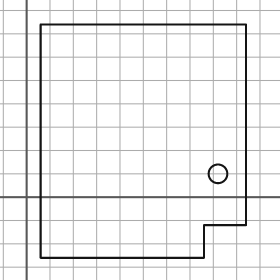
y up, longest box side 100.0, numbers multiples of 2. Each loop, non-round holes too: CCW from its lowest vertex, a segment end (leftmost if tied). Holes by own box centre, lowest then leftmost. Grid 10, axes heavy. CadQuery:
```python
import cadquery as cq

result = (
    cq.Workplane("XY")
    .moveTo(6.0, -26.0)
    .lineTo(76.0, -26.0)
    .lineTo(76.0, -12.0)
    .lineTo(94.0, -12.0)
    .lineTo(94.0, 74.0)
    .lineTo(6.0, 74.0)
    .close()
    .moveTo(82.0, 10.0)
    .circle(4.0)
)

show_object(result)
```